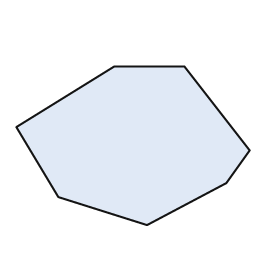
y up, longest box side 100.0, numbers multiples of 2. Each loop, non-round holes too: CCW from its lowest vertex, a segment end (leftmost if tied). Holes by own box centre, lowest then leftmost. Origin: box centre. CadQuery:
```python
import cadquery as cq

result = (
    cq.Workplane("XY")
    .moveTo(6.0, -34.0)
    .lineTo(40.0, -16.0)
    .lineTo(50.0, -2.0)
    .lineTo(22.0, 34.0)
    .lineTo(-8.0, 34.0)
    .lineTo(-50.0, 8.0)
    .lineTo(-32.0, -22.0)
    .close()
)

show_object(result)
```